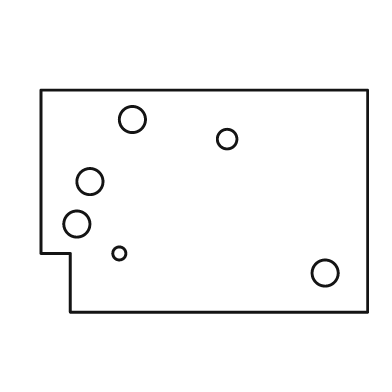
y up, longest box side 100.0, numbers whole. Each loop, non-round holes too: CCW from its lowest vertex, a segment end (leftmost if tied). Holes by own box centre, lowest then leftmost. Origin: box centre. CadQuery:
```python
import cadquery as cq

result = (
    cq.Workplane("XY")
    .moveTo(-41.0, -34.0)
    .lineTo(50.0, -34.0)
    .lineTo(50.0, 34.0)
    .lineTo(-50.0, 34.0)
    .lineTo(-50.0, -16.0)
    .lineTo(-41.0, -16.0)
    .close()
    .moveTo(37.0, -22.0)
    .circle(4.0)
    .moveTo(-26.0, -16.0)
    .circle(2.0)
    .moveTo(-39.0, -7.0)
    .circle(4.0)
    .moveTo(-35.0, 6.0)
    .circle(4.0)
    .moveTo(7.0, 19.0)
    .circle(3.0)
    .moveTo(-22.0, 25.0)
    .circle(4.0)
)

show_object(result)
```